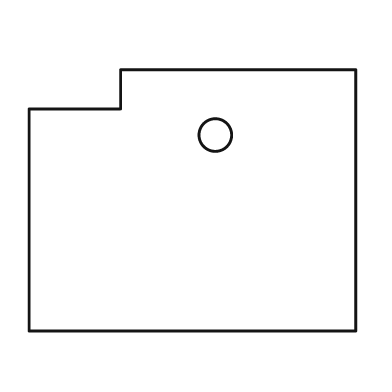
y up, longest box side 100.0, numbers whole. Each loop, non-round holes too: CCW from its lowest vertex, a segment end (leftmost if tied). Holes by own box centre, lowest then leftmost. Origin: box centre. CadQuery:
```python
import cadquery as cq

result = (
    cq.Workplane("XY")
    .moveTo(-50.0, -40.0)
    .lineTo(50.0, -40.0)
    .lineTo(50.0, 40.0)
    .lineTo(-22.0, 40.0)
    .lineTo(-22.0, 28.0)
    .lineTo(-50.0, 28.0)
    .close()
    .moveTo(7.0, 20.0)
    .circle(5.0)
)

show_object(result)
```